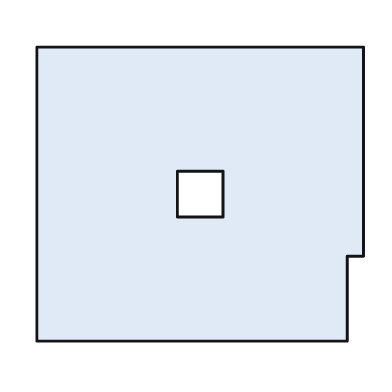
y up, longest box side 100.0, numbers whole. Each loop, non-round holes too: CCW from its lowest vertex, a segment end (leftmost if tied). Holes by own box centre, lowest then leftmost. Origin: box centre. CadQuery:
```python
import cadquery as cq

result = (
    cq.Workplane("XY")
    .moveTo(-50.0, -45.0)
    .lineTo(45.0, -45.0)
    .lineTo(45.0, -19.0)
    .lineTo(50.0, -19.0)
    .lineTo(50.0, 45.0)
    .lineTo(-50.0, 45.0)
    .close()
    .moveTo(-7.0, -7.0)
    .lineTo(7.0, -7.0)
    .lineTo(7.0, 7.0)
    .lineTo(-7.0, 7.0)
    .close()
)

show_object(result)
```